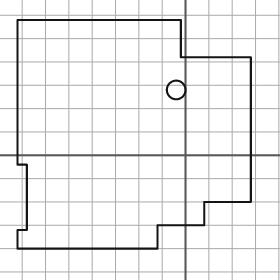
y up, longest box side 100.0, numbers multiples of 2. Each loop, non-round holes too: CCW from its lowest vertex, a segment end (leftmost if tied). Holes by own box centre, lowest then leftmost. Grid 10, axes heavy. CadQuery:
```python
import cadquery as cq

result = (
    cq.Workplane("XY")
    .moveTo(-72.0, -40.0)
    .lineTo(-12.0, -40.0)
    .lineTo(-12.0, -30.0)
    .lineTo(8.0, -30.0)
    .lineTo(8.0, -20.0)
    .lineTo(28.0, -20.0)
    .lineTo(28.0, 42.0)
    .lineTo(-2.0, 42.0)
    .lineTo(-2.0, 58.0)
    .lineTo(-72.0, 58.0)
    .lineTo(-72.0, -4.0)
    .lineTo(-68.0, -4.0)
    .lineTo(-68.0, -32.0)
    .lineTo(-72.0, -32.0)
    .close()
    .moveTo(-4.0, 28.0)
    .circle(4.0)
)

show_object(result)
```